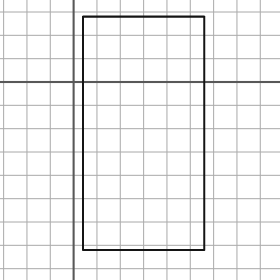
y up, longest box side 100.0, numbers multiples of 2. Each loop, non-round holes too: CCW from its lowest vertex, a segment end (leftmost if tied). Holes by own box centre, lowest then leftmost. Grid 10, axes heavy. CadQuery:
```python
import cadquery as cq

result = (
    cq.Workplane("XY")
    .moveTo(4.0, -72.0)
    .lineTo(56.0, -72.0)
    .lineTo(56.0, 28.0)
    .lineTo(4.0, 28.0)
    .close()
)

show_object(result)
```